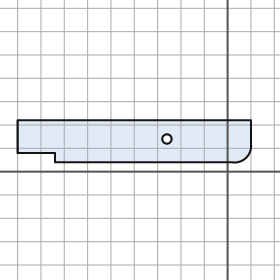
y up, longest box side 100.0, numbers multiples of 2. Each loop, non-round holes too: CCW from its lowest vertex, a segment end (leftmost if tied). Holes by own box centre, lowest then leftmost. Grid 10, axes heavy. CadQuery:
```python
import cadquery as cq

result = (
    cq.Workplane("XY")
    .moveTo(-74.0, 4.0)
    .lineTo(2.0, 4.0)
    .threePointArc((8.0, 6.0), (10.0, 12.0))
    .lineTo(10.0, 22.0)
    .lineTo(-90.0, 22.0)
    .lineTo(-90.0, 8.0)
    .lineTo(-74.0, 8.0)
    .close()
    .moveTo(-26.0, 14.0)
    .circle(2.0)
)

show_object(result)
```